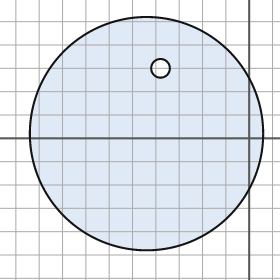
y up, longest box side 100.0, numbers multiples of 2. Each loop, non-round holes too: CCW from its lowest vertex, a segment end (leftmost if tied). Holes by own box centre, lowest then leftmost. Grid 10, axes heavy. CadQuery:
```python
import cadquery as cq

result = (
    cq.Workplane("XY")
    .moveTo(-44.0, 2.0)
    .circle(50.0)
    .moveTo(-38.0, 30.0)
    .circle(4.0)
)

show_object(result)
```